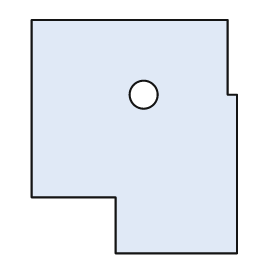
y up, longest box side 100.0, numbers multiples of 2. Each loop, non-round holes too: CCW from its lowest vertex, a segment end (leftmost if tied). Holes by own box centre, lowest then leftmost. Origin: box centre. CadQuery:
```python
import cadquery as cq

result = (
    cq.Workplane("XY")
    .moveTo(-8.0, -50.0)
    .lineTo(44.0, -50.0)
    .lineTo(44.0, 18.0)
    .lineTo(40.0, 18.0)
    .lineTo(40.0, 50.0)
    .lineTo(-44.0, 50.0)
    .lineTo(-44.0, -26.0)
    .lineTo(-8.0, -26.0)
    .close()
    .moveTo(4.0, 18.0)
    .circle(6.0)
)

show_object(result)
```